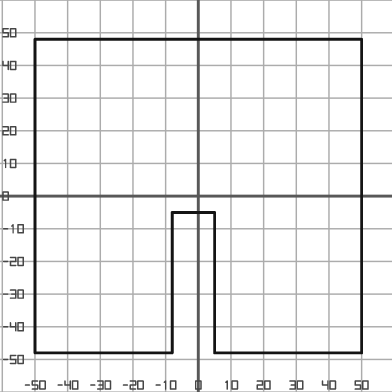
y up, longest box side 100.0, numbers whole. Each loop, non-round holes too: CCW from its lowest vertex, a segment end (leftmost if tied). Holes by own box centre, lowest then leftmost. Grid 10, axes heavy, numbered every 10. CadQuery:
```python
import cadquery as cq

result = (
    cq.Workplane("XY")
    .moveTo(-50.0, -48.0)
    .lineTo(-8.0, -48.0)
    .lineTo(-8.0, -5.0)
    .lineTo(5.0, -5.0)
    .lineTo(5.0, -48.0)
    .lineTo(50.0, -48.0)
    .lineTo(50.0, 48.0)
    .lineTo(-50.0, 48.0)
    .close()
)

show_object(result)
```